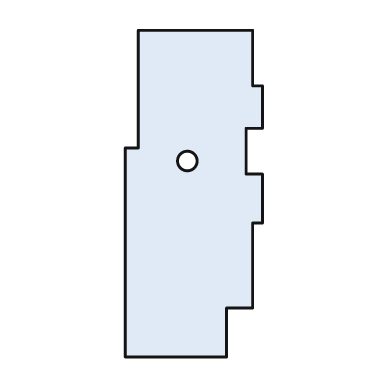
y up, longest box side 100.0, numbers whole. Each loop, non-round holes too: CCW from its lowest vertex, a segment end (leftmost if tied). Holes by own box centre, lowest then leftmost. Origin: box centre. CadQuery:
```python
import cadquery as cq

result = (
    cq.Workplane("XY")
    .moveTo(-21.0, -50.0)
    .lineTo(10.0, -50.0)
    .lineTo(10.0, -35.0)
    .lineTo(18.0, -35.0)
    .lineTo(18.0, -9.0)
    .lineTo(21.0, -9.0)
    .lineTo(21.0, 6.0)
    .lineTo(16.0, 6.0)
    .lineTo(16.0, 20.0)
    .lineTo(21.0, 20.0)
    .lineTo(21.0, 33.0)
    .lineTo(18.0, 33.0)
    .lineTo(18.0, 50.0)
    .lineTo(-17.0, 50.0)
    .lineTo(-17.0, 14.0)
    .lineTo(-21.0, 14.0)
    .close()
    .moveTo(-2.0, 10.0)
    .circle(3.0)
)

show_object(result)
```